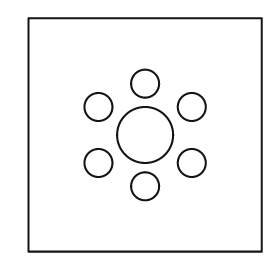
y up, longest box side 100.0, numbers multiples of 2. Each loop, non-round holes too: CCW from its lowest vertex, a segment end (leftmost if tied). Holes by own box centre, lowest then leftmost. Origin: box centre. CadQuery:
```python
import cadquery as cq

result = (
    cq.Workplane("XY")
    .moveTo(-50.0, -50.0)
    .lineTo(50.0, -50.0)
    .lineTo(50.0, 50.0)
    .lineTo(-50.0, 50.0)
    .close()
    .moveTo(0.0, -22.0)
    .circle(6.0)
    .moveTo(-20.0, -12.0)
    .circle(6.0)
    .moveTo(20.0, -12.0)
    .circle(6.0)
    .moveTo(0.0, 0.0)
    .circle(12.0)
    .moveTo(-20.0, 12.0)
    .circle(6.0)
    .moveTo(20.0, 12.0)
    .circle(6.0)
    .moveTo(0.0, 22.0)
    .circle(6.0)
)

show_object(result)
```